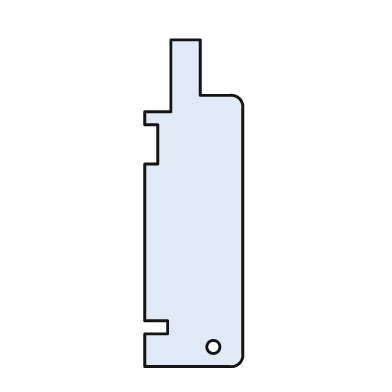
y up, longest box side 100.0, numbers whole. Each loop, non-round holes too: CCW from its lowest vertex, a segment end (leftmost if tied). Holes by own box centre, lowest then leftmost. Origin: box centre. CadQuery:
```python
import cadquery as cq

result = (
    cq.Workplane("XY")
    .moveTo(-15.0, -50.0)
    .lineTo(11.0, -50.0)
    .threePointArc((14.0, -49.0), (15.0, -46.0))
    .lineTo(15.0, 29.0)
    .threePointArc((14.0, 32.0), (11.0, 33.0))
    .lineTo(2.0, 33.0)
    .lineTo(2.0, 50.0)
    .lineTo(-7.0, 50.0)
    .lineTo(-7.0, 28.0)
    .lineTo(-15.0, 28.0)
    .lineTo(-15.0, 24.0)
    .lineTo(-11.0, 24.0)
    .lineTo(-11.0, 12.0)
    .lineTo(-15.0, 12.0)
    .lineTo(-15.0, -36.0)
    .lineTo(-8.0, -36.0)
    .lineTo(-8.0, -40.0)
    .lineTo(-15.0, -40.0)
    .close()
    .moveTo(6.0, -44.0)
    .circle(2.0)
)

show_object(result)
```